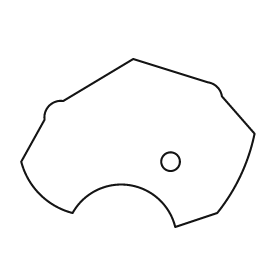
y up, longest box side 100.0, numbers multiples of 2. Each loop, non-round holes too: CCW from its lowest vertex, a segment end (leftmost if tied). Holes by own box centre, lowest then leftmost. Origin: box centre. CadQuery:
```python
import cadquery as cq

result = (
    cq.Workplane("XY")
    .moveTo(16.0, -36.0)
    .lineTo(34.0, -30.0)
    .threePointArc((44.0, -14.0), (50.0, 4.0))
    .lineTo(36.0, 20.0)
    .threePointArc((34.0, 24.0), (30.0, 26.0))
    .lineTo(-2.0, 36.0)
    .lineTo(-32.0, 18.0)
    .threePointArc((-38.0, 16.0), (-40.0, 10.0))
    .lineTo(-50.0, -8.0)
    .threePointArc((-42.0, -22.0), (-28.0, -30.0))
    .threePointArc((-4.0, -18.0), (16.0, -36.0))
    .close()
    .moveTo(14.0, -8.0)
    .circle(4.0)
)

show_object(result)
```